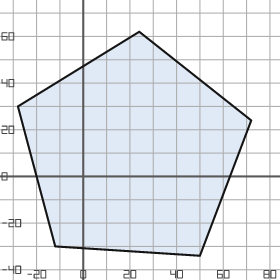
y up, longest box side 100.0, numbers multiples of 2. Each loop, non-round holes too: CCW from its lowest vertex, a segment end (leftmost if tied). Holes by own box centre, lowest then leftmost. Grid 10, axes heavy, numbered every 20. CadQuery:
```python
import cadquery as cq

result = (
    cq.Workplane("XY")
    .moveTo(50.0, -34.0)
    .lineTo(72.0, 24.0)
    .lineTo(24.0, 62.0)
    .lineTo(-28.0, 30.0)
    .lineTo(-12.0, -30.0)
    .close()
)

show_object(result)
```